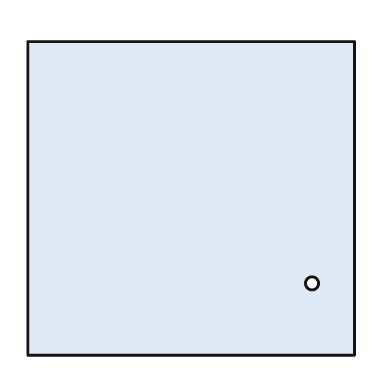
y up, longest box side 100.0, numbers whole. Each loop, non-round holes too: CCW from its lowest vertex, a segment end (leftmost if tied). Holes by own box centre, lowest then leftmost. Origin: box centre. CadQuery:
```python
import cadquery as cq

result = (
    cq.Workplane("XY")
    .moveTo(-50.0, -48.0)
    .lineTo(50.0, -48.0)
    .lineTo(50.0, 48.0)
    .lineTo(-50.0, 48.0)
    .close()
    .moveTo(37.0, -26.0)
    .circle(2.0)
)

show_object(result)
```